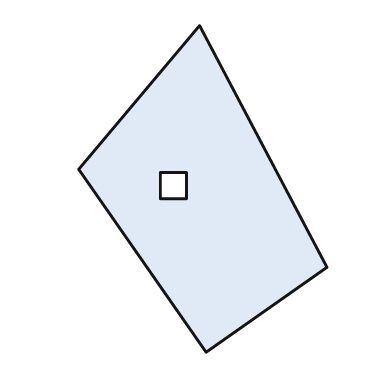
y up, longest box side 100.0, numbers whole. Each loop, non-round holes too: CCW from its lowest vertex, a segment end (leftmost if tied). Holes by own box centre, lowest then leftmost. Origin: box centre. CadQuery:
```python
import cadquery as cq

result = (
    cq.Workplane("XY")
    .moveTo(1.0, -50.0)
    .lineTo(38.0, -24.0)
    .lineTo(-1.0, 50.0)
    .lineTo(-38.0, 6.0)
    .close()
    .moveTo(-13.0, -3.0)
    .lineTo(-5.0, -3.0)
    .lineTo(-5.0, 5.0)
    .lineTo(-13.0, 5.0)
    .close()
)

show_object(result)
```